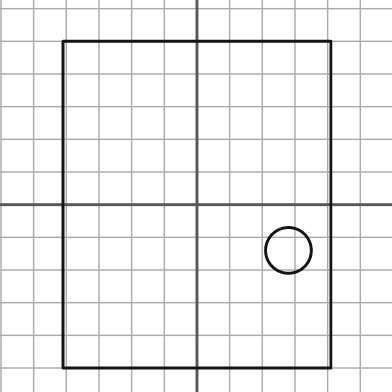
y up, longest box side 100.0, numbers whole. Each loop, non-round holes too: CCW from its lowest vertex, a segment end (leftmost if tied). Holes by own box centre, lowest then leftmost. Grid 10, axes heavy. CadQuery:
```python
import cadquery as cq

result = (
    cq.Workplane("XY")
    .moveTo(-41.0, -50.0)
    .lineTo(41.0, -50.0)
    .lineTo(41.0, 50.0)
    .lineTo(-41.0, 50.0)
    .close()
    .moveTo(28.0, -14.0)
    .circle(7.0)
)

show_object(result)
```